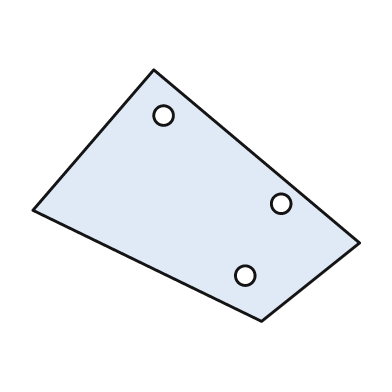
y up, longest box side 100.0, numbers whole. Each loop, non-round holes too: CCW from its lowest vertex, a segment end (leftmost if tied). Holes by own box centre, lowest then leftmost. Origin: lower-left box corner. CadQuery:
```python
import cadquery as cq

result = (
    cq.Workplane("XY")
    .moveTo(70.0, 0.0)
    .lineTo(100.0, 24.0)
    .lineTo(37.0, 77.0)
    .lineTo(0.0, 34.0)
    .close()
    .moveTo(65.0, 14.0)
    .circle(3.0)
    .moveTo(76.0, 36.0)
    .circle(3.0)
    .moveTo(40.0, 63.0)
    .circle(3.0)
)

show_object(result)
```